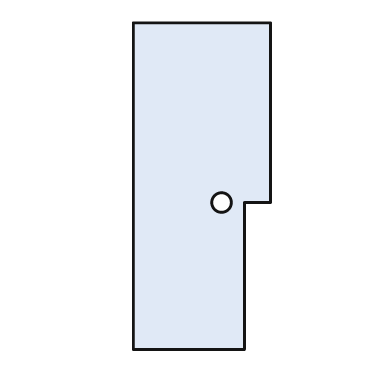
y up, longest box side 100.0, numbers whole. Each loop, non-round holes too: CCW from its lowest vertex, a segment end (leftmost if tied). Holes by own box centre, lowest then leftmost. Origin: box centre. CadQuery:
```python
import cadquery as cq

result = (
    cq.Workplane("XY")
    .moveTo(-21.0, -50.0)
    .lineTo(13.0, -50.0)
    .lineTo(13.0, -5.0)
    .lineTo(21.0, -5.0)
    .lineTo(21.0, 50.0)
    .lineTo(-21.0, 50.0)
    .close()
    .moveTo(6.0, -5.0)
    .circle(3.0)
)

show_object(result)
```